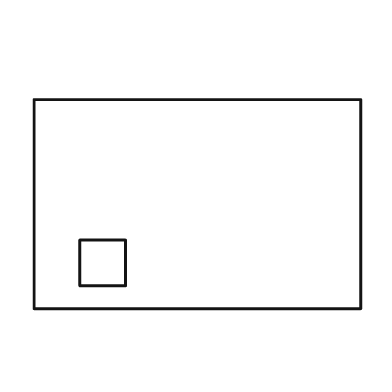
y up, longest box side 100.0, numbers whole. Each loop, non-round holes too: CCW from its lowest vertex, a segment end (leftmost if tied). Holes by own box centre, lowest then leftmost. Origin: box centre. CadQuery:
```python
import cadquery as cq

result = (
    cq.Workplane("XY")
    .moveTo(-50.0, -32.0)
    .lineTo(50.0, -32.0)
    .lineTo(50.0, 32.0)
    .lineTo(-50.0, 32.0)
    .close()
    .moveTo(-36.0, -25.0)
    .lineTo(-22.0, -25.0)
    .lineTo(-22.0, -11.0)
    .lineTo(-36.0, -11.0)
    .close()
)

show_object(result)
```